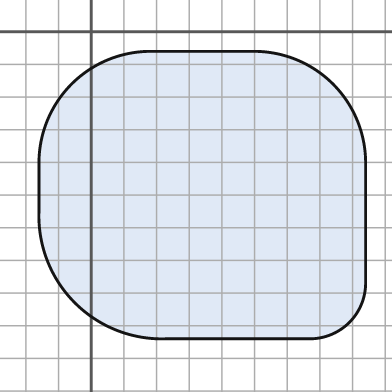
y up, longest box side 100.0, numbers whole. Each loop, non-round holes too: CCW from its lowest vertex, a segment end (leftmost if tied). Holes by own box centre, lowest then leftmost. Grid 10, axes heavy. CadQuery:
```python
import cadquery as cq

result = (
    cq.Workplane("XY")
    .moveTo(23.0, -94.0)
    .lineTo(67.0, -94.0)
    .threePointArc((79.0, -89.0), (84.0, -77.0))
    .lineTo(84.0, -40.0)
    .threePointArc((74.0, -16.0), (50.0, -6.0))
    .lineTo(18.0, -6.0)
    .threePointArc((-6.0, -16.0), (-16.0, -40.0))
    .lineTo(-16.0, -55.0)
    .threePointArc((-5.0, -83.0), (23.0, -94.0))
    .close()
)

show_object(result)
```